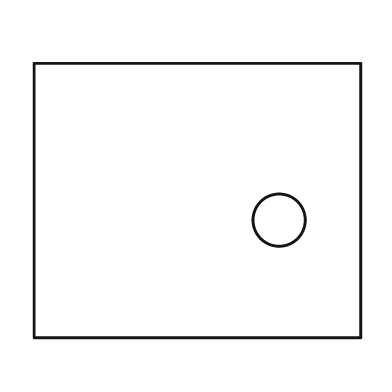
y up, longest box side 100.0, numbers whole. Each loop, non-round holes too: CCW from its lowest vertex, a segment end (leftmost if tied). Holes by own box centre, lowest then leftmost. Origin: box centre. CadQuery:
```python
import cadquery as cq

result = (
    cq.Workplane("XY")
    .moveTo(-50.0, -42.0)
    .lineTo(50.0, -42.0)
    .lineTo(50.0, 42.0)
    .lineTo(-50.0, 42.0)
    .close()
    .moveTo(25.0, -6.0)
    .circle(8.0)
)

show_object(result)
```